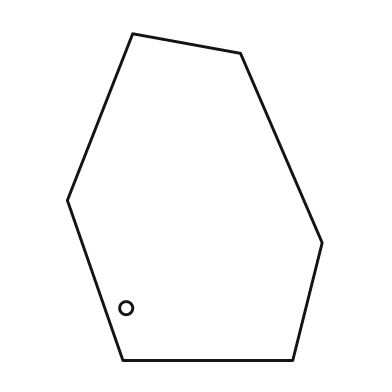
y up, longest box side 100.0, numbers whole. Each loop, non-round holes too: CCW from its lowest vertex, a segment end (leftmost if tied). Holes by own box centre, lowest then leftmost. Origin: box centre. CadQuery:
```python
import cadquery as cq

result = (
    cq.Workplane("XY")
    .moveTo(-22.0, -50.0)
    .lineTo(30.0, -50.0)
    .lineTo(39.0, -14.0)
    .lineTo(14.0, 44.0)
    .lineTo(-19.0, 50.0)
    .lineTo(-39.0, -1.0)
    .close()
    .moveTo(-21.0, -34.0)
    .circle(2.0)
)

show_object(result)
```